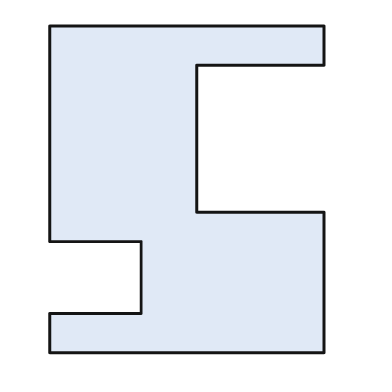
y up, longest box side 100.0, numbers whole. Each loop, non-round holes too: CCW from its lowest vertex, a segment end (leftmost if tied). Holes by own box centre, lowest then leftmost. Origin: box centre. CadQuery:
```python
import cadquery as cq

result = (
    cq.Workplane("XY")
    .moveTo(-42.0, -50.0)
    .lineTo(42.0, -50.0)
    .lineTo(42.0, -7.0)
    .lineTo(3.0, -7.0)
    .lineTo(3.0, 38.0)
    .lineTo(42.0, 38.0)
    .lineTo(42.0, 50.0)
    .lineTo(-42.0, 50.0)
    .lineTo(-42.0, -16.0)
    .lineTo(-14.0, -16.0)
    .lineTo(-14.0, -38.0)
    .lineTo(-42.0, -38.0)
    .close()
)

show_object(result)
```